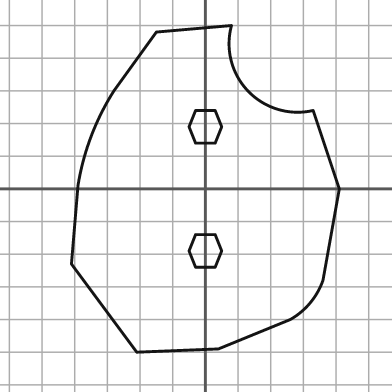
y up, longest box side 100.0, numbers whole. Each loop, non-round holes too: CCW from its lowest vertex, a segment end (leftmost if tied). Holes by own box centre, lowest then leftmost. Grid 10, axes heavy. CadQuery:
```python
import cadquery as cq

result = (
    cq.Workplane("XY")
    .moveTo(-21.0, -50.0)
    .lineTo(4.0, -49.0)
    .lineTo(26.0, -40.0)
    .threePointArc((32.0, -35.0), (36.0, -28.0))
    .lineTo(41.0, 0.0)
    .lineTo(33.0, 24.0)
    .threePointArc((13.0, 30.0), (8.0, 50.0))
    .lineTo(-15.0, 48.0)
    .lineTo(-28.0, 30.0)
    .threePointArc((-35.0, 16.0), (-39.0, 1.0))
    .lineTo(-41.0, -23.0)
    .close()
    .moveTo(-3.0, -24.0)
    .lineTo(3.0, -24.0)
    .lineTo(5.0, -19.0)
    .lineTo(3.0, -14.0)
    .lineTo(-3.0, -14.0)
    .lineTo(-5.0, -19.0)
    .close()
    .moveTo(-3.0, 14.0)
    .lineTo(3.0, 14.0)
    .lineTo(5.0, 19.0)
    .lineTo(3.0, 24.0)
    .lineTo(-3.0, 24.0)
    .lineTo(-5.0, 19.0)
    .close()
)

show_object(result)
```